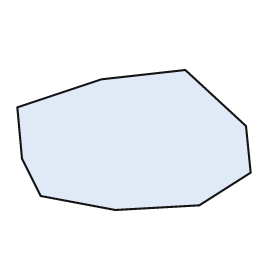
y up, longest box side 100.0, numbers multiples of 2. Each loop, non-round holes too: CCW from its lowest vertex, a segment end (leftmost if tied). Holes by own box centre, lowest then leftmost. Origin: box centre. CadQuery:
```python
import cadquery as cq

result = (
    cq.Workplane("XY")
    .moveTo(-8.0, -30.0)
    .lineTo(28.0, -28.0)
    .lineTo(50.0, -14.0)
    .lineTo(48.0, 6.0)
    .lineTo(22.0, 30.0)
    .lineTo(-14.0, 26.0)
    .lineTo(-50.0, 14.0)
    .lineTo(-48.0, -8.0)
    .lineTo(-40.0, -24.0)
    .close()
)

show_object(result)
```